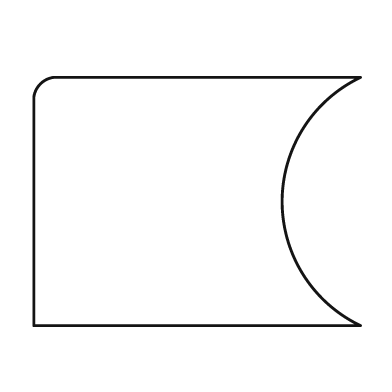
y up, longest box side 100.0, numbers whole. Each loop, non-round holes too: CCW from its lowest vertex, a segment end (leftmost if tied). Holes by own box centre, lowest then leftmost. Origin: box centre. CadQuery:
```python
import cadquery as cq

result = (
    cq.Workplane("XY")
    .moveTo(-50.0, -38.0)
    .lineTo(50.0, -38.0)
    .threePointArc((26.0, 0.0), (50.0, 38.0))
    .lineTo(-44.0, 38.0)
    .threePointArc((-48.0, 36.0), (-50.0, 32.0))
    .close()
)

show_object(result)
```